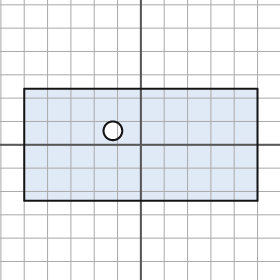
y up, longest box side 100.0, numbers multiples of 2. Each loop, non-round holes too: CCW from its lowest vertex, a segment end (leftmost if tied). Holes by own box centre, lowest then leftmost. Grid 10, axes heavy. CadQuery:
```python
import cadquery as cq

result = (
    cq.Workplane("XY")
    .moveTo(-50.0, -24.0)
    .lineTo(50.0, -24.0)
    .lineTo(50.0, 24.0)
    .lineTo(-50.0, 24.0)
    .close()
    .moveTo(-12.0, 6.0)
    .circle(4.0)
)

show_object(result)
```